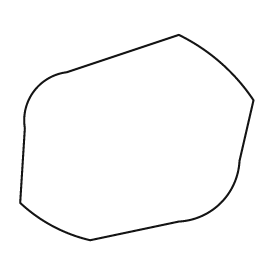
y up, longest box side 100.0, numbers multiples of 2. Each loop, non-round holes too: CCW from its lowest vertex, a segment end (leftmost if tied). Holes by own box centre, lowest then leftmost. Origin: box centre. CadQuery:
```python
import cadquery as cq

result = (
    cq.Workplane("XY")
    .moveTo(-20.0, -44.0)
    .lineTo(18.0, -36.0)
    .threePointArc((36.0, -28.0), (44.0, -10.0))
    .lineTo(50.0, 16.0)
    .threePointArc((36.0, 32.0), (18.0, 44.0))
    .lineTo(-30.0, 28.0)
    .threePointArc((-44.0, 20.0), (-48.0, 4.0))
    .lineTo(-50.0, -28.0)
    .threePointArc((-36.0, -38.0), (-20.0, -44.0))
    .close()
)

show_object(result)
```